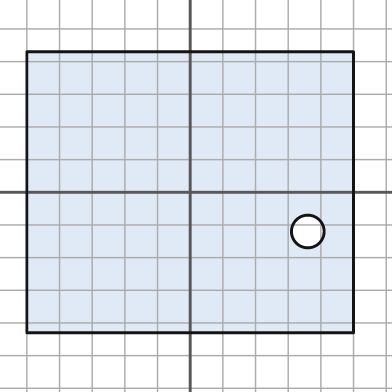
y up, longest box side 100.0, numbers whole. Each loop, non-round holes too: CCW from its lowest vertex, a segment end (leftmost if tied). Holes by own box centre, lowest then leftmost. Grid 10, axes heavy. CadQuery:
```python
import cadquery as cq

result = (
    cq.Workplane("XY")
    .moveTo(-50.0, -43.0)
    .lineTo(50.0, -43.0)
    .lineTo(50.0, 43.0)
    .lineTo(-50.0, 43.0)
    .close()
    .moveTo(36.0, -12.0)
    .circle(5.0)
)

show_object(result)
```